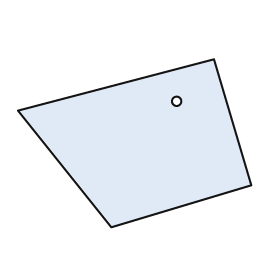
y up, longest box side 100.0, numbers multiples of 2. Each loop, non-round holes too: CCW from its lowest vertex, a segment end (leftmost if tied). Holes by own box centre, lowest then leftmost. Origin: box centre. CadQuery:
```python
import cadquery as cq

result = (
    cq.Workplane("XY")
    .moveTo(-10.0, -36.0)
    .lineTo(50.0, -18.0)
    .lineTo(34.0, 36.0)
    .lineTo(-50.0, 14.0)
    .close()
    .moveTo(18.0, 18.0)
    .circle(2.0)
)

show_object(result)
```